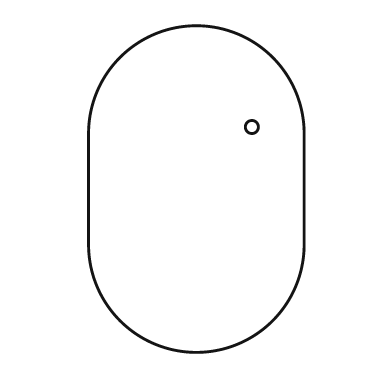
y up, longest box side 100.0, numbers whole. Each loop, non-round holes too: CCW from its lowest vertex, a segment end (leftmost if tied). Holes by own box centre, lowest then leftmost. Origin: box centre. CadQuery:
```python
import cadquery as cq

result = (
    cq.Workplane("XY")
    .moveTo(-33.0, -17.0)
    .threePointArc((0.0, -50.0), (33.0, -17.0))
    .lineTo(33.0, 17.0)
    .threePointArc((0.0, 50.0), (-33.0, 17.0))
    .close()
    .moveTo(17.0, 19.0)
    .circle(2.0)
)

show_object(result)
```